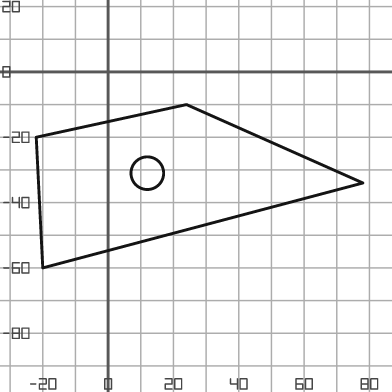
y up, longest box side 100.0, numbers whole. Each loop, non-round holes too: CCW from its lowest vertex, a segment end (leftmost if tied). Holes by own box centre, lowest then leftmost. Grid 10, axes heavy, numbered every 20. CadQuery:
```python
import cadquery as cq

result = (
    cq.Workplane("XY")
    .moveTo(-20.0, -60.0)
    .lineTo(78.0, -34.0)
    .lineTo(24.0, -10.0)
    .lineTo(-22.0, -20.0)
    .close()
    .moveTo(12.0, -31.0)
    .circle(5.0)
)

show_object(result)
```